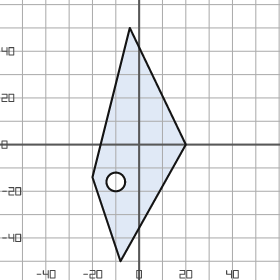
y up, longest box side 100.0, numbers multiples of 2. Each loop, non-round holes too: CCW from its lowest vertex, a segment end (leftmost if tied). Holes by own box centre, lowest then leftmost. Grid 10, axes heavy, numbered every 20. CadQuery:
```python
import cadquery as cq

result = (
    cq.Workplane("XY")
    .moveTo(-8.0, -50.0)
    .lineTo(20.0, 0.0)
    .lineTo(-4.0, 50.0)
    .lineTo(-20.0, -14.0)
    .close()
    .moveTo(-10.0, -16.0)
    .circle(4.0)
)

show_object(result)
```